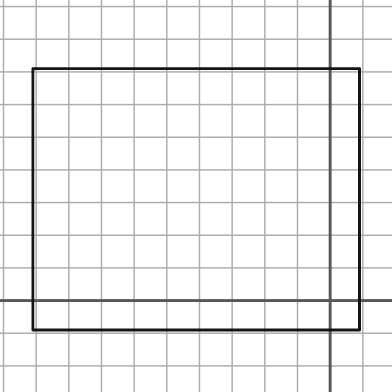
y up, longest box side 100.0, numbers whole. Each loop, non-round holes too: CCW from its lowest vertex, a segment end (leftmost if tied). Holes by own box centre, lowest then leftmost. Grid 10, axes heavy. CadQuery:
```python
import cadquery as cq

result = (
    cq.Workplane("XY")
    .moveTo(-91.0, -9.0)
    .lineTo(9.0, -9.0)
    .lineTo(9.0, 71.0)
    .lineTo(-91.0, 71.0)
    .close()
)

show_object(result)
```